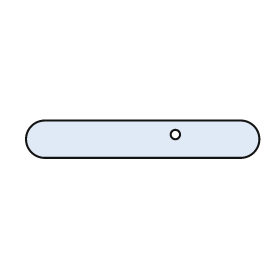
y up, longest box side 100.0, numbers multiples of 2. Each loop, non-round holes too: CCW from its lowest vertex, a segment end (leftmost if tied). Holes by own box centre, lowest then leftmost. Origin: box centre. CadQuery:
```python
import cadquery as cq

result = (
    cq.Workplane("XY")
    .moveTo(-42.0, -8.0)
    .lineTo(42.0, -8.0)
    .threePointArc((50.0, 0.0), (42.0, 8.0))
    .lineTo(-42.0, 8.0)
    .threePointArc((-50.0, 0.0), (-42.0, -8.0))
    .close()
    .moveTo(14.0, 2.0)
    .circle(2.0)
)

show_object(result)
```